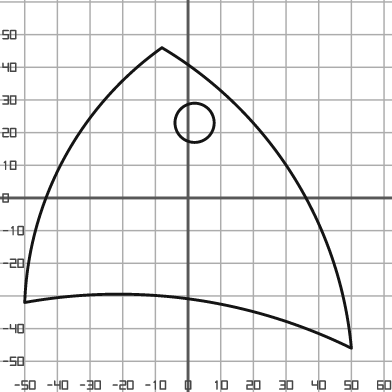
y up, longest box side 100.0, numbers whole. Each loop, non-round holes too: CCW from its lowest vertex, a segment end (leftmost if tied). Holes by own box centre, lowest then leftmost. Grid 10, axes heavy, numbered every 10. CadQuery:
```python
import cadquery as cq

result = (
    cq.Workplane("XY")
    .moveTo(50.0, -46.0)
    .threePointArc((32.0, 7.0), (-8.0, 46.0))
    .threePointArc((-38.0, 12.0), (-50.0, -32.0))
    .threePointArc((1.0, -31.0), (50.0, -46.0))
    .close()
    .moveTo(2.0, 23.0)
    .circle(6.0)
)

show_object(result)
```